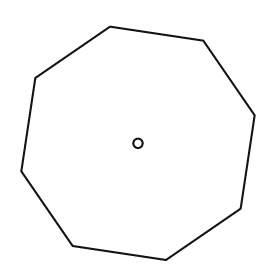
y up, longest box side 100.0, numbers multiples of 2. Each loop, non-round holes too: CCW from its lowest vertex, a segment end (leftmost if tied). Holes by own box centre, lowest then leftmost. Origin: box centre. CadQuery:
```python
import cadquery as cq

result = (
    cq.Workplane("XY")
    .moveTo(12.0, -50.0)
    .lineTo(44.0, -28.0)
    .lineTo(50.0, 12.0)
    .lineTo(28.0, 44.0)
    .lineTo(-12.0, 50.0)
    .lineTo(-44.0, 28.0)
    .lineTo(-50.0, -12.0)
    .lineTo(-28.0, -44.0)
    .close()
    .moveTo(0.0, 0.0)
    .circle(2.0)
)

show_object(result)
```